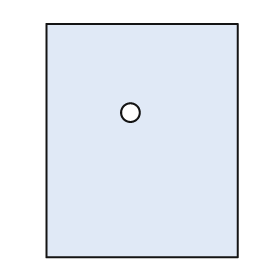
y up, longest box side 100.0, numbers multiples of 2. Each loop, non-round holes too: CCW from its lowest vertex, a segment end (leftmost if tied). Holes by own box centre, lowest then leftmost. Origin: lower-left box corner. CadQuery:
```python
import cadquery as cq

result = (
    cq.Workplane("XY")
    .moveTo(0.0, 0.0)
    .lineTo(82.0, 0.0)
    .lineTo(82.0, 100.0)
    .lineTo(0.0, 100.0)
    .close()
    .moveTo(36.0, 62.0)
    .circle(4.0)
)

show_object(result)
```